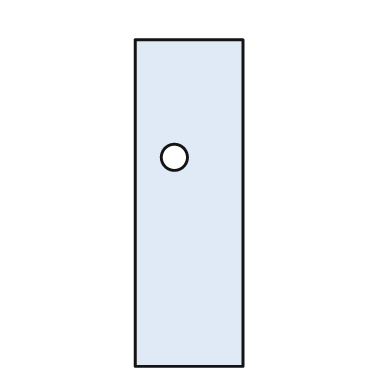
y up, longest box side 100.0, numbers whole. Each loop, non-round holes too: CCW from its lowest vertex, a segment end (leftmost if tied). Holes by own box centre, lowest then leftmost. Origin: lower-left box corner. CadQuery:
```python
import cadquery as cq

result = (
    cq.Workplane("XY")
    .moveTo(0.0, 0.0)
    .lineTo(33.0, 0.0)
    .lineTo(33.0, 100.0)
    .lineTo(0.0, 100.0)
    .close()
    .moveTo(12.0, 64.0)
    .circle(4.0)
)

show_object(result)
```